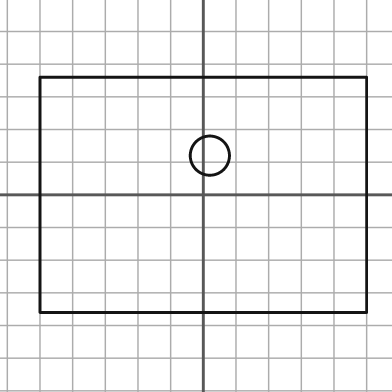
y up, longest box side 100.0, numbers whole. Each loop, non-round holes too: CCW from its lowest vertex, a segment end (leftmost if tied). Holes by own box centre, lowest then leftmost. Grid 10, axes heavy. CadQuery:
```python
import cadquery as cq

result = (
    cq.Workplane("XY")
    .moveTo(-50.0, -36.0)
    .lineTo(50.0, -36.0)
    .lineTo(50.0, 36.0)
    .lineTo(-50.0, 36.0)
    .close()
    .moveTo(2.0, 12.0)
    .circle(6.0)
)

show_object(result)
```